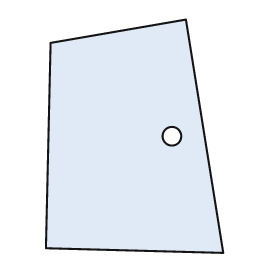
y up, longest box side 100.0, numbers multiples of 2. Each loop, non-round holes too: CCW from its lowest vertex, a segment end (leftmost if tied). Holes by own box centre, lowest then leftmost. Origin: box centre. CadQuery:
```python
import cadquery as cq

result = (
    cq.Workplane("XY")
    .moveTo(38.0, -50.0)
    .lineTo(22.0, 50.0)
    .lineTo(-36.0, 40.0)
    .lineTo(-38.0, -48.0)
    .close()
    .moveTo(16.0, 0.0)
    .circle(4.0)
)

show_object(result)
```